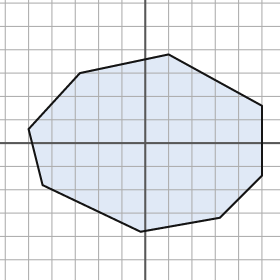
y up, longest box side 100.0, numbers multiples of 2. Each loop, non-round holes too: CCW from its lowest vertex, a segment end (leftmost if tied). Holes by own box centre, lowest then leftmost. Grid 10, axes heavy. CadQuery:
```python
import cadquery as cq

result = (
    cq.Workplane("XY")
    .moveTo(-2.0, -38.0)
    .lineTo(32.0, -32.0)
    .lineTo(50.0, -14.0)
    .lineTo(50.0, 16.0)
    .lineTo(10.0, 38.0)
    .lineTo(-28.0, 30.0)
    .lineTo(-50.0, 6.0)
    .lineTo(-44.0, -18.0)
    .close()
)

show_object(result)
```